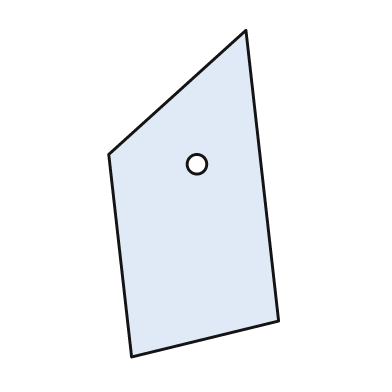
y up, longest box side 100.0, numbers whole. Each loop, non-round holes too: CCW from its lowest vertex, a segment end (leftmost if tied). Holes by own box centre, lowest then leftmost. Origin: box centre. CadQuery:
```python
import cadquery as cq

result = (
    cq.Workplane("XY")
    .moveTo(-19.0, -50.0)
    .lineTo(26.0, -39.0)
    .lineTo(16.0, 50.0)
    .lineTo(-26.0, 12.0)
    .close()
    .moveTo(1.0, 9.0)
    .circle(3.0)
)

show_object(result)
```